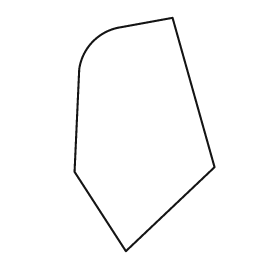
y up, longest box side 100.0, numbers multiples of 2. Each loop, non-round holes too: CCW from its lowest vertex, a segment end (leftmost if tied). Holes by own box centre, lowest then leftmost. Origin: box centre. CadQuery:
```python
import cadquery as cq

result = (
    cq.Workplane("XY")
    .moveTo(-8.0, -50.0)
    .lineTo(30.0, -14.0)
    .lineTo(12.0, 50.0)
    .lineTo(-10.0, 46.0)
    .threePointArc((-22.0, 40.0), (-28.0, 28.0))
    .lineTo(-30.0, -16.0)
    .close()
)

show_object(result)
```